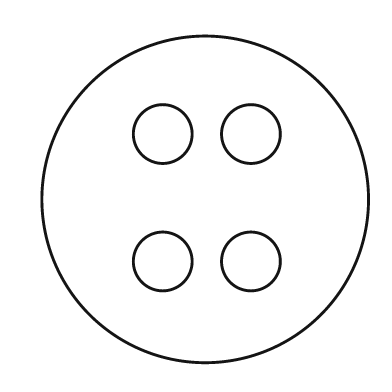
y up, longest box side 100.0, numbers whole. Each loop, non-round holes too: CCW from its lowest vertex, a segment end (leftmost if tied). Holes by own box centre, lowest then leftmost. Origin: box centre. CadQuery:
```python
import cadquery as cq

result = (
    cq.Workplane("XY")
    .moveTo(0.0, 0.0)
    .circle(50.0)
    .moveTo(-13.0, -19.0)
    .circle(9.0)
    .moveTo(14.0, -19.0)
    .circle(9.0)
    .moveTo(-13.0, 20.0)
    .circle(9.0)
    .moveTo(14.0, 20.0)
    .circle(9.0)
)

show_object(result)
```